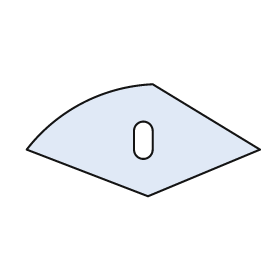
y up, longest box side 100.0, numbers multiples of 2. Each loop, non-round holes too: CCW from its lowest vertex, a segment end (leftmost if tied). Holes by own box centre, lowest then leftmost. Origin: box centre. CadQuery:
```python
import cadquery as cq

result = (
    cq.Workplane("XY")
    .moveTo(2.0, -24.0)
    .lineTo(50.0, -4.0)
    .lineTo(4.0, 24.0)
    .threePointArc((-26.0, 16.0), (-50.0, -4.0))
    .close()
    .moveTo(-4.0, -4.0)
    .threePointArc((0.0, -8.0), (4.0, -4.0))
    .lineTo(4.0, 4.0)
    .threePointArc((0.0, 8.0), (-4.0, 4.0))
    .close()
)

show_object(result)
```